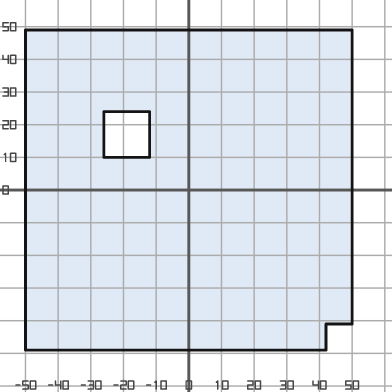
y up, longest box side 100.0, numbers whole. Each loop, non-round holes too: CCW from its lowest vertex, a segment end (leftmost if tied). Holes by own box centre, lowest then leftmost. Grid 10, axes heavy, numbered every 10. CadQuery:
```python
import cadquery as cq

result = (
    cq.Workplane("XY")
    .moveTo(-50.0, -49.0)
    .lineTo(42.0, -49.0)
    .lineTo(42.0, -41.0)
    .lineTo(50.0, -41.0)
    .lineTo(50.0, 49.0)
    .lineTo(-50.0, 49.0)
    .close()
    .moveTo(-26.0, 10.0)
    .lineTo(-12.0, 10.0)
    .lineTo(-12.0, 24.0)
    .lineTo(-26.0, 24.0)
    .close()
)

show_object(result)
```